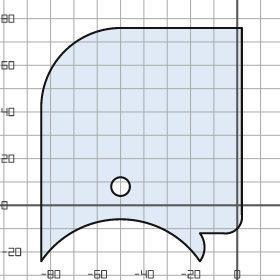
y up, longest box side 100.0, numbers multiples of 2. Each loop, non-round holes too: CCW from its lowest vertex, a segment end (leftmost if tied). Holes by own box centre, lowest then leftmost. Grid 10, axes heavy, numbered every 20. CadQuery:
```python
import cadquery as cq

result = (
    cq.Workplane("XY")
    .moveTo(-84.0, -24.0)
    .threePointArc((-50.0, -6.0), (-16.0, -24.0))
    .threePointArc((-14.0, -18.0), (-16.0, -12.0))
    .lineTo(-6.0, -12.0)
    .threePointArc((0.0, -10.0), (2.0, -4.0))
    .lineTo(2.0, 76.0)
    .lineTo(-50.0, 76.0)
    .threePointArc((-74.0, 66.0), (-84.0, 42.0))
    .close()
    .moveTo(-50.0, 8.0)
    .circle(4.0)
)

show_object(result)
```